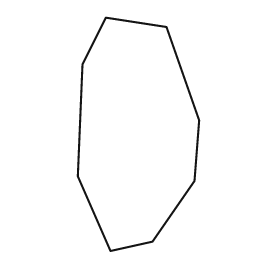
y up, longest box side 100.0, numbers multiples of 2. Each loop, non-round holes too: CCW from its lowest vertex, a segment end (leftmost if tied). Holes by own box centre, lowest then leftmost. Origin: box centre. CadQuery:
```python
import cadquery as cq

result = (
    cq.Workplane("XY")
    .moveTo(-12.0, -50.0)
    .lineTo(6.0, -46.0)
    .lineTo(24.0, -20.0)
    .lineTo(26.0, 6.0)
    .lineTo(12.0, 46.0)
    .lineTo(-14.0, 50.0)
    .lineTo(-24.0, 30.0)
    .lineTo(-26.0, -18.0)
    .close()
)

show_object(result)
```